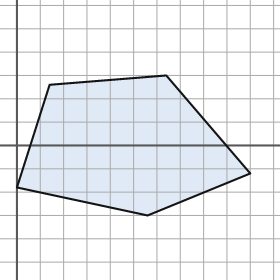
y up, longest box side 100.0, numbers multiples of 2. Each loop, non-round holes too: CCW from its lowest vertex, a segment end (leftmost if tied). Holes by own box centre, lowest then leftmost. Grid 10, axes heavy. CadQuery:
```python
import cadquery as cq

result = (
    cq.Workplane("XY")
    .moveTo(56.0, -30.0)
    .lineTo(100.0, -12.0)
    .lineTo(64.0, 30.0)
    .lineTo(14.0, 26.0)
    .lineTo(0.0, -18.0)
    .close()
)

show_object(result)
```